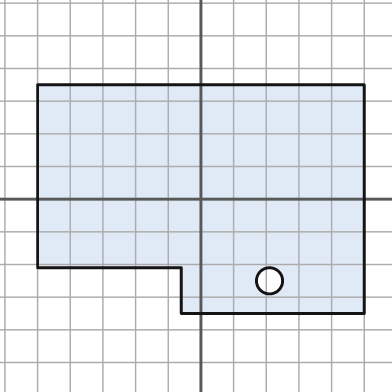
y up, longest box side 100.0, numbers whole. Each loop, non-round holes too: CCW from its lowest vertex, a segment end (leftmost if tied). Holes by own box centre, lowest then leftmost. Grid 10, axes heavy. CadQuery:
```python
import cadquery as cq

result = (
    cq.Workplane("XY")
    .moveTo(-6.0, -35.0)
    .lineTo(50.0, -35.0)
    .lineTo(50.0, 35.0)
    .lineTo(-50.0, 35.0)
    .lineTo(-50.0, -21.0)
    .lineTo(-6.0, -21.0)
    .close()
    .moveTo(21.0, -25.0)
    .circle(4.0)
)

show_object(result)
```